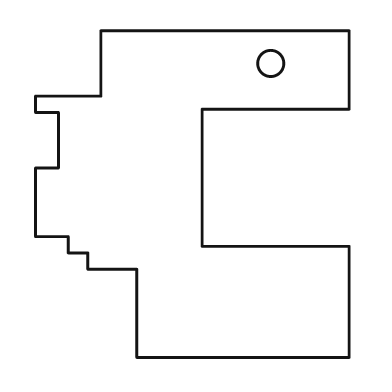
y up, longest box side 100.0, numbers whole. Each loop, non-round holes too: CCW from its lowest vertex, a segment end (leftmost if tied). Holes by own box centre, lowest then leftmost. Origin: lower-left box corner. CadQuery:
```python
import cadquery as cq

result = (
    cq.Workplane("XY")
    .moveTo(31.0, 0.0)
    .lineTo(96.0, 0.0)
    .lineTo(96.0, 34.0)
    .lineTo(51.0, 34.0)
    .lineTo(51.0, 76.0)
    .lineTo(96.0, 76.0)
    .lineTo(96.0, 100.0)
    .lineTo(20.0, 100.0)
    .lineTo(20.0, 80.0)
    .lineTo(0.0, 80.0)
    .lineTo(0.0, 75.0)
    .lineTo(7.0, 75.0)
    .lineTo(7.0, 58.0)
    .lineTo(0.0, 58.0)
    .lineTo(0.0, 37.0)
    .lineTo(10.0, 37.0)
    .lineTo(10.0, 32.0)
    .lineTo(16.0, 32.0)
    .lineTo(16.0, 27.0)
    .lineTo(31.0, 27.0)
    .close()
    .moveTo(72.0, 90.0)
    .circle(4.0)
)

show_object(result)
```